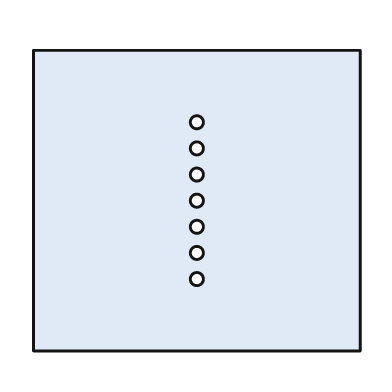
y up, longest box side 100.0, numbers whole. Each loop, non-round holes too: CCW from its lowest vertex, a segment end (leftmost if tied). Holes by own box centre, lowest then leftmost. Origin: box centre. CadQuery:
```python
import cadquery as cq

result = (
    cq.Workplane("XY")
    .moveTo(-50.0, -46.0)
    .lineTo(50.0, -46.0)
    .lineTo(50.0, 46.0)
    .lineTo(-50.0, 46.0)
    .close()
    .moveTo(0.0, -24.0)
    .circle(2.0)
    .moveTo(0.0, -16.0)
    .circle(2.0)
    .moveTo(0.0, -8.0)
    .circle(2.0)
    .moveTo(0.0, 0.0)
    .circle(2.0)
    .moveTo(0.0, 8.0)
    .circle(2.0)
    .moveTo(0.0, 16.0)
    .circle(2.0)
    .moveTo(0.0, 24.0)
    .circle(2.0)
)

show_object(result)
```